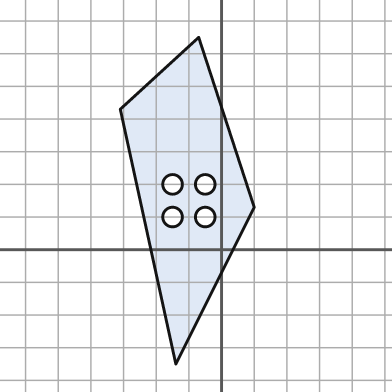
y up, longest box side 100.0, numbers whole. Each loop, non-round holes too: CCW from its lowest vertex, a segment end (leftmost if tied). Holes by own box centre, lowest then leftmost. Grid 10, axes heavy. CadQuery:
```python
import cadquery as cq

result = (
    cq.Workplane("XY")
    .moveTo(-14.0, -35.0)
    .lineTo(10.0, 13.0)
    .lineTo(-7.0, 65.0)
    .lineTo(-31.0, 43.0)
    .close()
    .moveTo(-15.0, 10.0)
    .circle(3.0)
    .moveTo(-5.0, 10.0)
    .circle(3.0)
    .moveTo(-15.0, 20.0)
    .circle(3.0)
    .moveTo(-5.0, 20.0)
    .circle(3.0)
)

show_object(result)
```